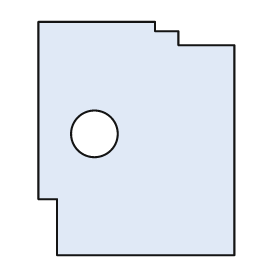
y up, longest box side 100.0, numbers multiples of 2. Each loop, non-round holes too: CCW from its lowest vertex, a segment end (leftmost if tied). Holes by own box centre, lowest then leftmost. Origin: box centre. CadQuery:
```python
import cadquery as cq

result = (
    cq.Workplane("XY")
    .moveTo(-34.0, -50.0)
    .lineTo(42.0, -50.0)
    .lineTo(42.0, 40.0)
    .lineTo(18.0, 40.0)
    .lineTo(18.0, 46.0)
    .lineTo(8.0, 46.0)
    .lineTo(8.0, 50.0)
    .lineTo(-42.0, 50.0)
    .lineTo(-42.0, -26.0)
    .lineTo(-34.0, -26.0)
    .close()
    .moveTo(-18.0, 2.0)
    .circle(10.0)
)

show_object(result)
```